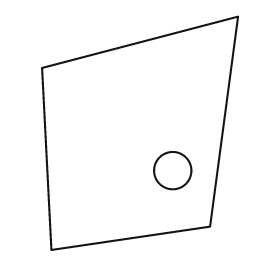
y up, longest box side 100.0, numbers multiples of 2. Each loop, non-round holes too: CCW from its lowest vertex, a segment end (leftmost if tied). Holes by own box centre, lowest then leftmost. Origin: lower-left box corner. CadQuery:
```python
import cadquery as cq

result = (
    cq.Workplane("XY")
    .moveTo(4.0, 0.0)
    .lineTo(72.0, 10.0)
    .lineTo(84.0, 100.0)
    .lineTo(0.0, 78.0)
    .close()
    .moveTo(56.0, 34.0)
    .circle(8.0)
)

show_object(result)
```